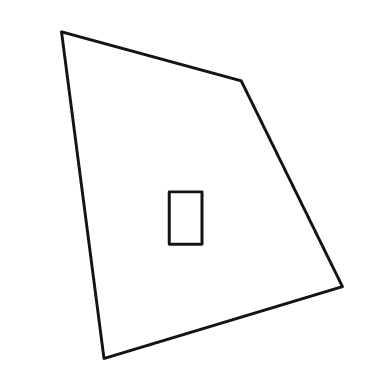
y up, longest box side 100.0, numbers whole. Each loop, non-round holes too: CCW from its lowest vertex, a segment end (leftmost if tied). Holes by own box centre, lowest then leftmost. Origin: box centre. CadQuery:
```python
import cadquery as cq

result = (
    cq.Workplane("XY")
    .moveTo(-30.0, -50.0)
    .lineTo(43.0, -28.0)
    .lineTo(12.0, 35.0)
    .lineTo(-43.0, 50.0)
    .close()
    .moveTo(-10.0, -15.0)
    .lineTo(0.0, -15.0)
    .lineTo(0.0, 1.0)
    .lineTo(-10.0, 1.0)
    .close()
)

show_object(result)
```